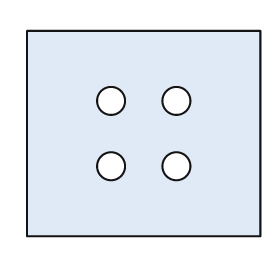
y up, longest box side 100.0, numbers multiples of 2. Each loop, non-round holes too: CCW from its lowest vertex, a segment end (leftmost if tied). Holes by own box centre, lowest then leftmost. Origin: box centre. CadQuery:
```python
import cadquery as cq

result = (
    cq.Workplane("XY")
    .moveTo(-50.0, -44.0)
    .lineTo(50.0, -44.0)
    .lineTo(50.0, 44.0)
    .lineTo(-50.0, 44.0)
    .close()
    .moveTo(-14.0, -14.0)
    .circle(6.0)
    .moveTo(14.0, -14.0)
    .circle(6.0)
    .moveTo(-14.0, 14.0)
    .circle(6.0)
    .moveTo(14.0, 14.0)
    .circle(6.0)
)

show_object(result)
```